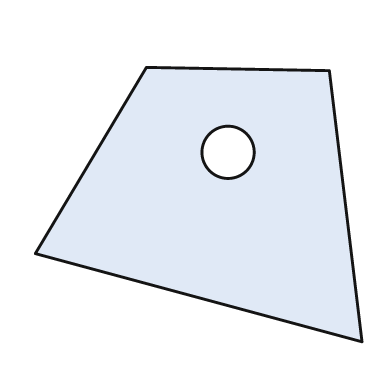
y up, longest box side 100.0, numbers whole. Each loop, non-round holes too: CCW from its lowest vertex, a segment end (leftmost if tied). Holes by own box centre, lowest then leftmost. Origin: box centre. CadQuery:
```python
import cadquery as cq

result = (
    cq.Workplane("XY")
    .moveTo(50.0, -42.0)
    .lineTo(40.0, 41.0)
    .lineTo(-16.0, 42.0)
    .lineTo(-50.0, -15.0)
    .close()
    .moveTo(9.0, 16.0)
    .circle(8.0)
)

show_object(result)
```